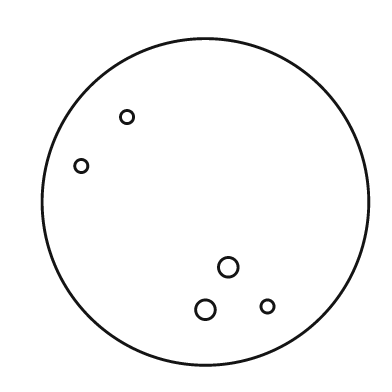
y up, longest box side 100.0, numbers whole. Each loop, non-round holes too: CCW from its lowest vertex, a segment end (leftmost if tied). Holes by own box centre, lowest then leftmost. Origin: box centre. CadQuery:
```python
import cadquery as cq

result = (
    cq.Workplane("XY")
    .moveTo(0.0, 0.0)
    .circle(50.0)
    .moveTo(0.0, -33.0)
    .circle(3.0)
    .moveTo(19.0, -32.0)
    .circle(2.0)
    .moveTo(7.0, -20.0)
    .circle(3.0)
    .moveTo(-38.0, 11.0)
    .circle(2.0)
    .moveTo(-24.0, 26.0)
    .circle(2.0)
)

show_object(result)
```